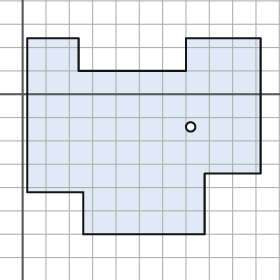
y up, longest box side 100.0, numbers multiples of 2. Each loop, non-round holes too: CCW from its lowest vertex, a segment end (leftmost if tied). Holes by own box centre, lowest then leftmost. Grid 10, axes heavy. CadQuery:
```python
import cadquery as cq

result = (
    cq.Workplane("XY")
    .moveTo(26.0, -60.0)
    .lineTo(78.0, -60.0)
    .lineTo(78.0, -34.0)
    .lineTo(102.0, -34.0)
    .lineTo(102.0, 24.0)
    .lineTo(70.0, 24.0)
    .lineTo(70.0, 10.0)
    .lineTo(24.0, 10.0)
    .lineTo(24.0, 24.0)
    .lineTo(2.0, 24.0)
    .lineTo(2.0, -42.0)
    .lineTo(26.0, -42.0)
    .close()
    .moveTo(72.0, -14.0)
    .circle(2.0)
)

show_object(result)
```